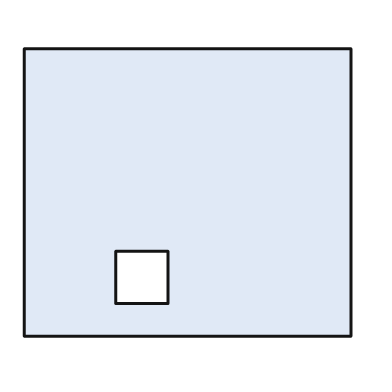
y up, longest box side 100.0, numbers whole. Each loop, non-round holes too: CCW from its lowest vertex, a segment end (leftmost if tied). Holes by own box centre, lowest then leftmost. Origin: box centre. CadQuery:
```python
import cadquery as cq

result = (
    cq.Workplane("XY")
    .moveTo(-50.0, -44.0)
    .lineTo(50.0, -44.0)
    .lineTo(50.0, 44.0)
    .lineTo(-50.0, 44.0)
    .close()
    .moveTo(-22.0, -34.0)
    .lineTo(-6.0, -34.0)
    .lineTo(-6.0, -18.0)
    .lineTo(-22.0, -18.0)
    .close()
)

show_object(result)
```